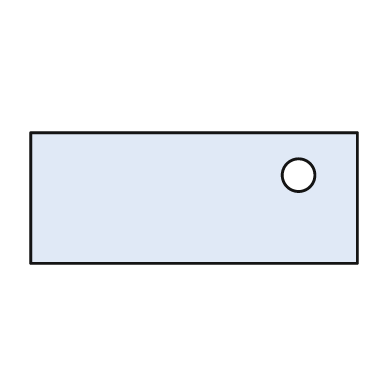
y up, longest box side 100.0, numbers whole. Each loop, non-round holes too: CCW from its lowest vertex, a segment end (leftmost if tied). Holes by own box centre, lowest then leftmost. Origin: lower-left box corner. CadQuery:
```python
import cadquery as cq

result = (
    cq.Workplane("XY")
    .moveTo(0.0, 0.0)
    .lineTo(100.0, 0.0)
    .lineTo(100.0, 40.0)
    .lineTo(0.0, 40.0)
    .close()
    .moveTo(82.0, 27.0)
    .circle(5.0)
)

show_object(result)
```